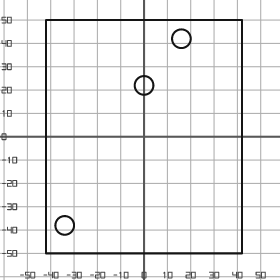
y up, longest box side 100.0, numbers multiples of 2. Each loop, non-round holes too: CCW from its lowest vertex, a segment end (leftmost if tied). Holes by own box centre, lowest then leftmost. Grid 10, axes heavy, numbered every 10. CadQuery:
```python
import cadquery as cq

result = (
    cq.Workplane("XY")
    .moveTo(-42.0, -50.0)
    .lineTo(42.0, -50.0)
    .lineTo(42.0, 50.0)
    .lineTo(-42.0, 50.0)
    .close()
    .moveTo(-34.0, -38.0)
    .circle(4.0)
    .moveTo(0.0, 22.0)
    .circle(4.0)
    .moveTo(16.0, 42.0)
    .circle(4.0)
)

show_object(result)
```